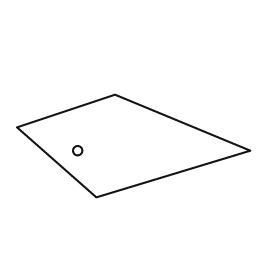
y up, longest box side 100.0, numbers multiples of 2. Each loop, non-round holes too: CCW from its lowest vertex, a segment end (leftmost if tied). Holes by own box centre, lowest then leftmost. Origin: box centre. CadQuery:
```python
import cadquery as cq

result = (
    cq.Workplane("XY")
    .moveTo(-16.0, -22.0)
    .lineTo(50.0, -2.0)
    .lineTo(-8.0, 22.0)
    .lineTo(-50.0, 8.0)
    .close()
    .moveTo(-24.0, -2.0)
    .circle(2.0)
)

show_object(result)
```